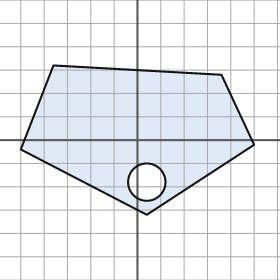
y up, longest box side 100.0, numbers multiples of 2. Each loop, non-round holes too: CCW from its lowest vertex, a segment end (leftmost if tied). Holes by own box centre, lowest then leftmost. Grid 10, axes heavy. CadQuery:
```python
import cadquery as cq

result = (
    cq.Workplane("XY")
    .moveTo(4.0, -32.0)
    .lineTo(50.0, -2.0)
    .lineTo(36.0, 28.0)
    .lineTo(-36.0, 32.0)
    .lineTo(-50.0, -4.0)
    .close()
    .moveTo(4.0, -18.0)
    .circle(8.0)
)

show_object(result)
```